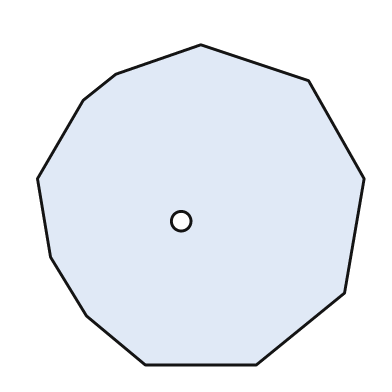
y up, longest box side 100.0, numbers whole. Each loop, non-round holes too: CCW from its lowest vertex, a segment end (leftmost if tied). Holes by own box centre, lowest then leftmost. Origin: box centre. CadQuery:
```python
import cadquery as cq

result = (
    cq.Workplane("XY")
    .moveTo(-17.0, -49.0)
    .lineTo(17.0, -49.0)
    .lineTo(44.0, -27.0)
    .lineTo(50.0, 8.0)
    .lineTo(33.0, 38.0)
    .lineTo(0.0, 49.0)
    .lineTo(-26.0, 40.0)
    .lineTo(-36.0, 32.0)
    .lineTo(-50.0, 8.0)
    .lineTo(-46.0, -16.0)
    .lineTo(-35.0, -34.0)
    .close()
    .moveTo(-6.0, -5.0)
    .circle(3.0)
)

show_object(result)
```